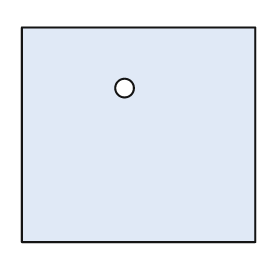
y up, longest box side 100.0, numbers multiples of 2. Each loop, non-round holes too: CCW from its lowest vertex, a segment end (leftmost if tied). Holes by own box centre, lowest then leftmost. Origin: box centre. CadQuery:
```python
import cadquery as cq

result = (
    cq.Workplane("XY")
    .moveTo(-50.0, -46.0)
    .lineTo(50.0, -46.0)
    .lineTo(50.0, 46.0)
    .lineTo(-50.0, 46.0)
    .close()
    .moveTo(-6.0, 20.0)
    .circle(4.0)
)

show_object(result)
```